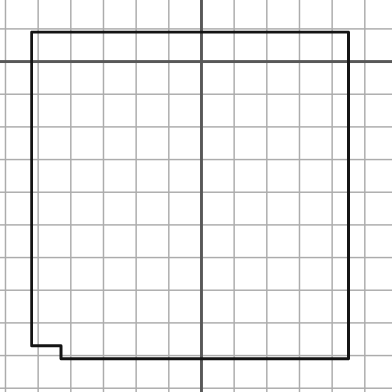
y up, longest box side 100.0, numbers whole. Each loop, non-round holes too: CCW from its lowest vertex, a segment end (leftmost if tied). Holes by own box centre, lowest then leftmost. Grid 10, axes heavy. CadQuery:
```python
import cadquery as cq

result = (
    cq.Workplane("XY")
    .moveTo(-43.0, -91.0)
    .lineTo(45.0, -91.0)
    .lineTo(45.0, 9.0)
    .lineTo(-52.0, 9.0)
    .lineTo(-52.0, -87.0)
    .lineTo(-43.0, -87.0)
    .close()
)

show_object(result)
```